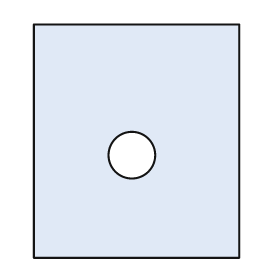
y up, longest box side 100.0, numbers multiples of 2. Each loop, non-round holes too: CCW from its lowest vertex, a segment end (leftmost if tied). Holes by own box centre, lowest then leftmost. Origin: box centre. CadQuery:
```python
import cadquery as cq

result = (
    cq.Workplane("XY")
    .moveTo(-44.0, -50.0)
    .lineTo(44.0, -50.0)
    .lineTo(44.0, 50.0)
    .lineTo(-44.0, 50.0)
    .close()
    .moveTo(-2.0, -6.0)
    .circle(10.0)
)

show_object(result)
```